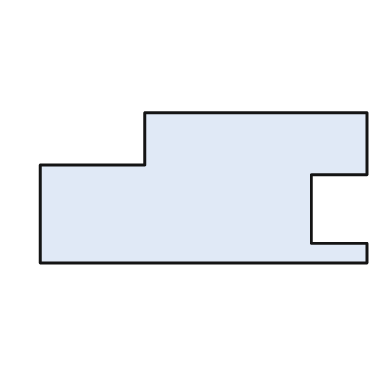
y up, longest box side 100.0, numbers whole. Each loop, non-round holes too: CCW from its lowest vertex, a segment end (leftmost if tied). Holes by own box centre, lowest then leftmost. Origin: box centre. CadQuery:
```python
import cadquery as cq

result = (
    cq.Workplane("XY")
    .moveTo(-50.0, -23.0)
    .lineTo(50.0, -23.0)
    .lineTo(50.0, -17.0)
    .lineTo(33.0, -17.0)
    .lineTo(33.0, 4.0)
    .lineTo(50.0, 4.0)
    .lineTo(50.0, 23.0)
    .lineTo(-18.0, 23.0)
    .lineTo(-18.0, 7.0)
    .lineTo(-50.0, 7.0)
    .close()
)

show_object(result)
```